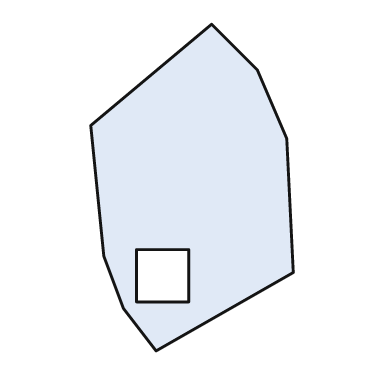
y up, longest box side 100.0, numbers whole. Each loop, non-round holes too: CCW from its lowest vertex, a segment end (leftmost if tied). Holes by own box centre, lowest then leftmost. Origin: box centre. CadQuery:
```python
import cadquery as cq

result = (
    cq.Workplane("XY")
    .moveTo(-11.0, -50.0)
    .lineTo(31.0, -26.0)
    .lineTo(29.0, 15.0)
    .lineTo(20.0, 36.0)
    .lineTo(6.0, 50.0)
    .lineTo(-31.0, 19.0)
    .lineTo(-27.0, -21.0)
    .lineTo(-21.0, -37.0)
    .close()
    .moveTo(-17.0, -35.0)
    .lineTo(-1.0, -35.0)
    .lineTo(-1.0, -19.0)
    .lineTo(-17.0, -19.0)
    .close()
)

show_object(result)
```